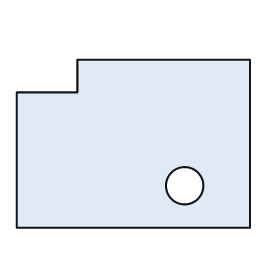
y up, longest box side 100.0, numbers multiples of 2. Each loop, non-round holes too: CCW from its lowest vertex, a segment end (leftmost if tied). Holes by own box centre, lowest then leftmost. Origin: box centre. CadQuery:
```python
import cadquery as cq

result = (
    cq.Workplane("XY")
    .moveTo(-50.0, -36.0)
    .lineTo(50.0, -36.0)
    .lineTo(50.0, 36.0)
    .lineTo(-24.0, 36.0)
    .lineTo(-24.0, 22.0)
    .lineTo(-50.0, 22.0)
    .close()
    .moveTo(22.0, -18.0)
    .circle(8.0)
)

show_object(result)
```